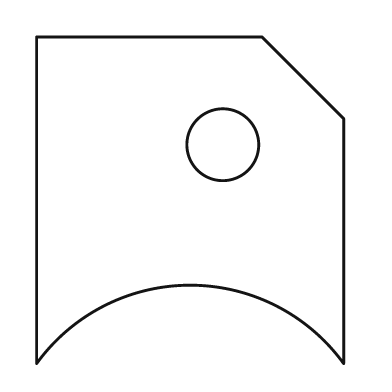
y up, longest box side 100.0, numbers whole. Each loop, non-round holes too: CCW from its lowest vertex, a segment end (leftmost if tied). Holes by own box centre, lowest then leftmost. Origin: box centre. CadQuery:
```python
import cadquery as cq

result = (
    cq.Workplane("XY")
    .moveTo(-47.0, -50.0)
    .threePointArc((0.0, -26.0), (47.0, -50.0))
    .lineTo(47.0, 25.0)
    .lineTo(22.0, 50.0)
    .lineTo(-47.0, 50.0)
    .close()
    .moveTo(10.0, 17.0)
    .circle(11.0)
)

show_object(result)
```